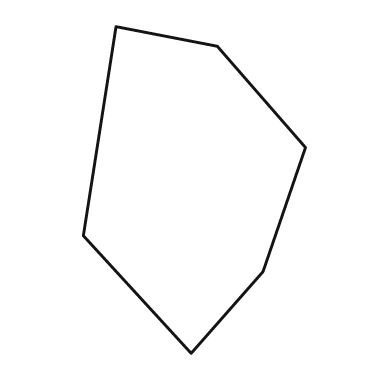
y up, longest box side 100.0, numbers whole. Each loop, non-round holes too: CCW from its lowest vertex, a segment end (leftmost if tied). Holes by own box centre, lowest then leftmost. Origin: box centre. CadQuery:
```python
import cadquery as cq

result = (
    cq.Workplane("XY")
    .moveTo(-1.0, -50.0)
    .lineTo(21.0, -25.0)
    .lineTo(34.0, 13.0)
    .lineTo(7.0, 44.0)
    .lineTo(-24.0, 50.0)
    .lineTo(-34.0, -14.0)
    .close()
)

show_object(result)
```